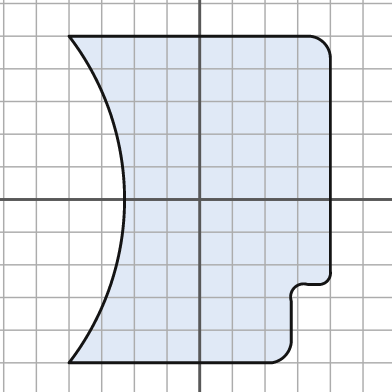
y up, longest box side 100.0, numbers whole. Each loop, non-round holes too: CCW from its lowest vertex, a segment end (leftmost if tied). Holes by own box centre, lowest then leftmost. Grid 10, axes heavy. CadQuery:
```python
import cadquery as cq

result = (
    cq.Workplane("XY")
    .moveTo(-40.0, -50.0)
    .lineTo(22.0, -50.0)
    .threePointArc((26.0, -48.0), (28.0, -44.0))
    .lineTo(28.0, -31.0)
    .threePointArc((29.0, -27.0), (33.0, -26.0))
    .lineTo(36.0, -26.0)
    .threePointArc((39.0, -25.0), (40.0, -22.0))
    .lineTo(40.0, 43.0)
    .threePointArc((38.0, 48.0), (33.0, 50.0))
    .lineTo(-40.0, 50.0)
    .threePointArc((-23.0, 0.0), (-40.0, -50.0))
    .close()
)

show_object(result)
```